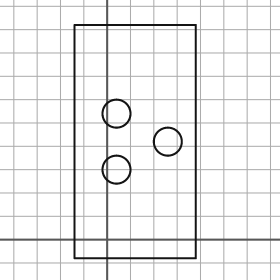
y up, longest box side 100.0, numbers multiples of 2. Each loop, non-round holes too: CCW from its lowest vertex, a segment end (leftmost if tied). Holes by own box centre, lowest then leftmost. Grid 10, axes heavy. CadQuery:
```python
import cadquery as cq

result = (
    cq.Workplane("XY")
    .moveTo(-14.0, -8.0)
    .lineTo(38.0, -8.0)
    .lineTo(38.0, 92.0)
    .lineTo(-14.0, 92.0)
    .close()
    .moveTo(4.0, 30.0)
    .circle(6.0)
    .moveTo(26.0, 42.0)
    .circle(6.0)
    .moveTo(4.0, 54.0)
    .circle(6.0)
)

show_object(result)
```